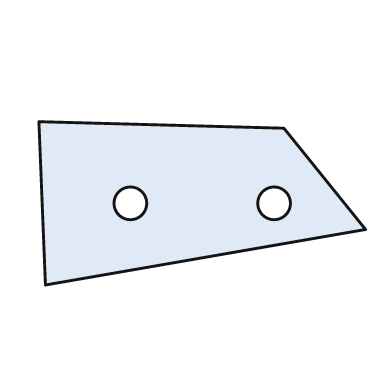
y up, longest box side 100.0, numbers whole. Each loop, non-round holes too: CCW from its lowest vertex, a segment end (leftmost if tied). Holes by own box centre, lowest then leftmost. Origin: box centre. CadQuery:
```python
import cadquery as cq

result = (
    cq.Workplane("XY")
    .moveTo(-48.0, -25.0)
    .lineTo(50.0, -8.0)
    .lineTo(25.0, 23.0)
    .lineTo(-50.0, 25.0)
    .close()
    .moveTo(-22.0, 0.0)
    .circle(5.0)
    .moveTo(22.0, 0.0)
    .circle(5.0)
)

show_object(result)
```